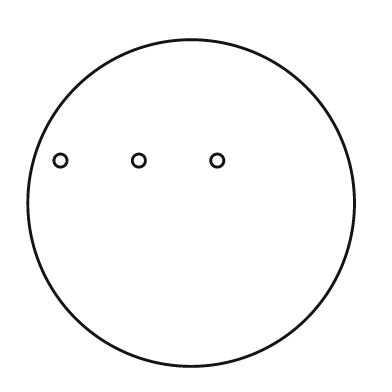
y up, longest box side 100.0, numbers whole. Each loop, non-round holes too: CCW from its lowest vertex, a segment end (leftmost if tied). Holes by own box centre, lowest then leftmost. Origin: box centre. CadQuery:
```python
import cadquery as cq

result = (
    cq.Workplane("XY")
    .moveTo(0.0, 0.0)
    .circle(50.0)
    .moveTo(-40.0, 13.0)
    .circle(2.0)
    .moveTo(-16.0, 13.0)
    .circle(2.0)
    .moveTo(8.0, 13.0)
    .circle(2.0)
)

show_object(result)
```